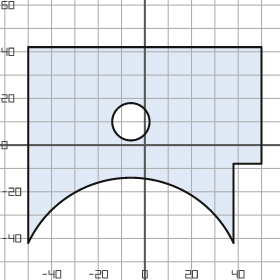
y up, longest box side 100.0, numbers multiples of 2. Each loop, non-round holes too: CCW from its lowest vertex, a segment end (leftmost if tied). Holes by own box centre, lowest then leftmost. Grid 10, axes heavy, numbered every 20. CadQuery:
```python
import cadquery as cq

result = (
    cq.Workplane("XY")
    .moveTo(-50.0, -42.0)
    .threePointArc((-6.0, -14.0), (38.0, -42.0))
    .lineTo(38.0, -8.0)
    .lineTo(50.0, -8.0)
    .lineTo(50.0, 42.0)
    .lineTo(-50.0, 42.0)
    .close()
    .moveTo(-6.0, 10.0)
    .circle(8.0)
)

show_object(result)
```